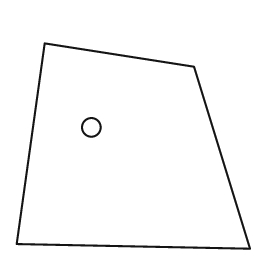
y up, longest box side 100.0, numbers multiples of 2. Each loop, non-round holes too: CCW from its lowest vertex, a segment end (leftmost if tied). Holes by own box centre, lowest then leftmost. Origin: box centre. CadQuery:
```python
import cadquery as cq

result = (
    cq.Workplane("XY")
    .moveTo(50.0, -44.0)
    .lineTo(26.0, 34.0)
    .lineTo(-38.0, 44.0)
    .lineTo(-50.0, -42.0)
    .close()
    .moveTo(-18.0, 8.0)
    .circle(4.0)
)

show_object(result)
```